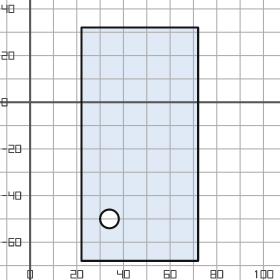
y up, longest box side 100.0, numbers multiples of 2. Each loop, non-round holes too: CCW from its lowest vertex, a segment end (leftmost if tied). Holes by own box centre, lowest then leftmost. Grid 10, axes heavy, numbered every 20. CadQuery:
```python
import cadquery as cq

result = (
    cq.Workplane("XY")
    .moveTo(22.0, -68.0)
    .lineTo(72.0, -68.0)
    .lineTo(72.0, 32.0)
    .lineTo(22.0, 32.0)
    .close()
    .moveTo(34.0, -50.0)
    .circle(4.0)
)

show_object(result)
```